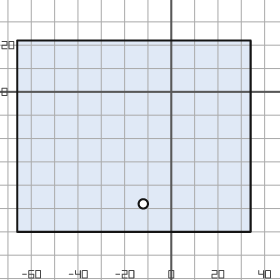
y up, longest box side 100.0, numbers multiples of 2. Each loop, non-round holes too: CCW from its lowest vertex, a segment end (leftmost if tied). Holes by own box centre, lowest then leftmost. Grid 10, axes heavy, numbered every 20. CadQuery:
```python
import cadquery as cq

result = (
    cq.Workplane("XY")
    .moveTo(-66.0, -60.0)
    .lineTo(34.0, -60.0)
    .lineTo(34.0, 22.0)
    .lineTo(-66.0, 22.0)
    .close()
    .moveTo(-12.0, -48.0)
    .circle(2.0)
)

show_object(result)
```